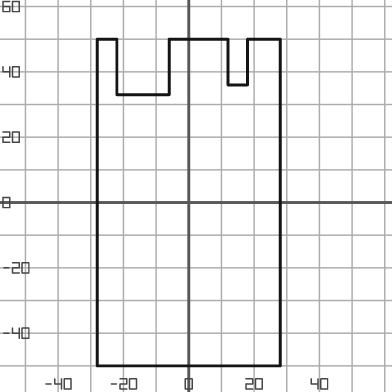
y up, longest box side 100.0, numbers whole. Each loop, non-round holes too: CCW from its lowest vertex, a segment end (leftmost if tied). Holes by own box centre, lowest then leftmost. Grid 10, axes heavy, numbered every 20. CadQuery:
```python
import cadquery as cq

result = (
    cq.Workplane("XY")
    .moveTo(-28.0, -50.0)
    .lineTo(28.0, -50.0)
    .lineTo(28.0, 50.0)
    .lineTo(18.0, 50.0)
    .lineTo(18.0, 36.0)
    .lineTo(12.0, 36.0)
    .lineTo(12.0, 50.0)
    .lineTo(-6.0, 50.0)
    .lineTo(-6.0, 33.0)
    .lineTo(-22.0, 33.0)
    .lineTo(-22.0, 50.0)
    .lineTo(-28.0, 50.0)
    .close()
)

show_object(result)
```